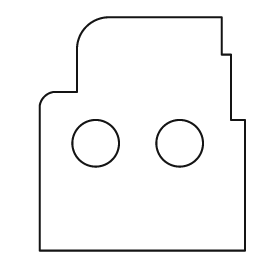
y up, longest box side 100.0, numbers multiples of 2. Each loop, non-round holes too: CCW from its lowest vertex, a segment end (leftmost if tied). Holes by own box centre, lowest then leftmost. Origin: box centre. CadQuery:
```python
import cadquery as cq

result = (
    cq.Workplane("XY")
    .moveTo(-44.0, -50.0)
    .lineTo(44.0, -50.0)
    .lineTo(44.0, 6.0)
    .lineTo(38.0, 6.0)
    .lineTo(38.0, 34.0)
    .lineTo(34.0, 34.0)
    .lineTo(34.0, 50.0)
    .lineTo(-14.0, 50.0)
    .threePointArc((-24.0, 46.0), (-28.0, 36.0))
    .lineTo(-28.0, 18.0)
    .lineTo(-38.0, 18.0)
    .threePointArc((-42.0, 16.0), (-44.0, 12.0))
    .close()
    .moveTo(-20.0, -4.0)
    .circle(10.0)
    .moveTo(16.0, -4.0)
    .circle(10.0)
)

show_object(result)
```